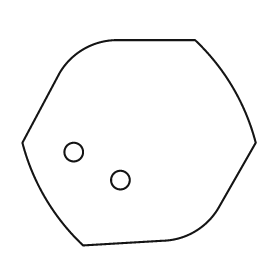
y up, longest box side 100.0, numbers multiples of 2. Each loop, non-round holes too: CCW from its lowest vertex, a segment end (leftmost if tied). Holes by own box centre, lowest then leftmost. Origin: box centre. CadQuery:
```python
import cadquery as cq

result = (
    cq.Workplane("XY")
    .moveTo(-24.0, -44.0)
    .lineTo(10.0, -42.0)
    .threePointArc((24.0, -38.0), (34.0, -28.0))
    .lineTo(50.0, 0.0)
    .threePointArc((40.0, 24.0), (24.0, 44.0))
    .lineTo(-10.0, 44.0)
    .threePointArc((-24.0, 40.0), (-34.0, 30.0))
    .lineTo(-50.0, 0.0)
    .threePointArc((-40.0, -24.0), (-24.0, -44.0))
    .close()
    .moveTo(-8.0, -16.0)
    .circle(4.0)
    .moveTo(-28.0, -4.0)
    .circle(4.0)
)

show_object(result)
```